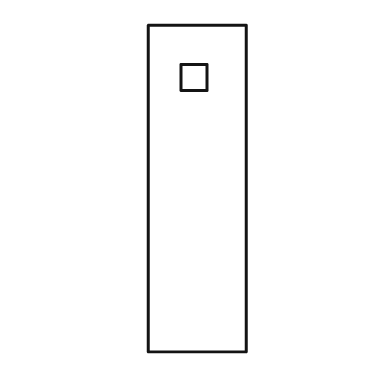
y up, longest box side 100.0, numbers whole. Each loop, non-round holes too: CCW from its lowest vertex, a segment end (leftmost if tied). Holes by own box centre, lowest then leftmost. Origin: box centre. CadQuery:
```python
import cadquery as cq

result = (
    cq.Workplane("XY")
    .moveTo(-15.0, -50.0)
    .lineTo(15.0, -50.0)
    .lineTo(15.0, 50.0)
    .lineTo(-15.0, 50.0)
    .close()
    .moveTo(-5.0, 30.0)
    .lineTo(3.0, 30.0)
    .lineTo(3.0, 38.0)
    .lineTo(-5.0, 38.0)
    .close()
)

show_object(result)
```